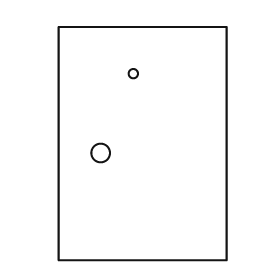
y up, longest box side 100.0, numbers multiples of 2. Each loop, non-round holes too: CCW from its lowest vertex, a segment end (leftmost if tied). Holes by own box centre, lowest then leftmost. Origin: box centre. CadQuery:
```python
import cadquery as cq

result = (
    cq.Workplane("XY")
    .moveTo(-36.0, -50.0)
    .lineTo(36.0, -50.0)
    .lineTo(36.0, 50.0)
    .lineTo(-36.0, 50.0)
    .close()
    .moveTo(-18.0, -4.0)
    .circle(4.0)
    .moveTo(-4.0, 30.0)
    .circle(2.0)
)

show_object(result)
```